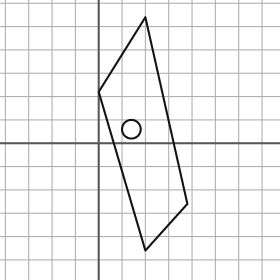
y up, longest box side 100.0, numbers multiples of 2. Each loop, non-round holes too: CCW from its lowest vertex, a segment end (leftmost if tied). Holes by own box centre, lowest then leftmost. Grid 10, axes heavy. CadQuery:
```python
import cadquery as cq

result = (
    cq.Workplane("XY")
    .moveTo(20.0, -46.0)
    .lineTo(38.0, -26.0)
    .lineTo(20.0, 54.0)
    .lineTo(0.0, 22.0)
    .close()
    .moveTo(14.0, 6.0)
    .circle(4.0)
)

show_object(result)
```